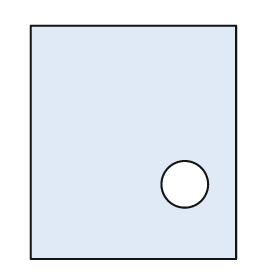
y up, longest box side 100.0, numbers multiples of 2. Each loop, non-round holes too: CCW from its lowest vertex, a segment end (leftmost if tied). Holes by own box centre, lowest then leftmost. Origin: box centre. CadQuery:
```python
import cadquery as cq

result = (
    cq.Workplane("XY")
    .moveTo(-44.0, -50.0)
    .lineTo(44.0, -50.0)
    .lineTo(44.0, 50.0)
    .lineTo(-44.0, 50.0)
    .close()
    .moveTo(22.0, -18.0)
    .circle(10.0)
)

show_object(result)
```